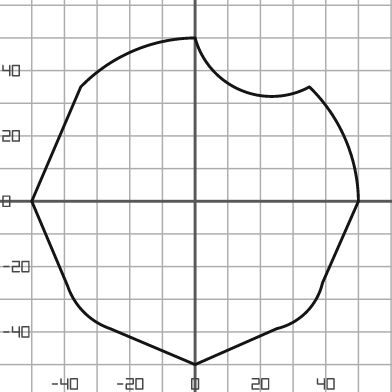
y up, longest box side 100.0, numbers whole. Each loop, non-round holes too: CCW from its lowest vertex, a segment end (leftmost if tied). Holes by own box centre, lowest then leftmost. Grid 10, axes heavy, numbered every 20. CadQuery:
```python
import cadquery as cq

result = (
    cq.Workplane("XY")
    .moveTo(0.0, -50.0)
    .lineTo(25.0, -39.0)
    .threePointArc((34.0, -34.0), (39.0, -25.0))
    .lineTo(50.0, 0.0)
    .threePointArc((46.0, 19.0), (35.0, 35.0))
    .threePointArc((14.0, 34.0), (0.0, 50.0))
    .threePointArc((-19.0, 46.0), (-35.0, 35.0))
    .lineTo(-50.0, 0.0)
    .lineTo(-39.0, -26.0)
    .threePointArc((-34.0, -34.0), (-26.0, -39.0))
    .close()
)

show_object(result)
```